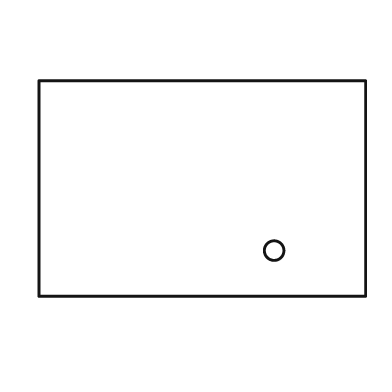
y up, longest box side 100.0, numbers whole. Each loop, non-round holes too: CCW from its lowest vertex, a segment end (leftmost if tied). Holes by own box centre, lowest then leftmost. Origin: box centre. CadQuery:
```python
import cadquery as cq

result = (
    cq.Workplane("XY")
    .moveTo(-50.0, -33.0)
    .lineTo(50.0, -33.0)
    .lineTo(50.0, 33.0)
    .lineTo(-50.0, 33.0)
    .close()
    .moveTo(22.0, -19.0)
    .circle(3.0)
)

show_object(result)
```